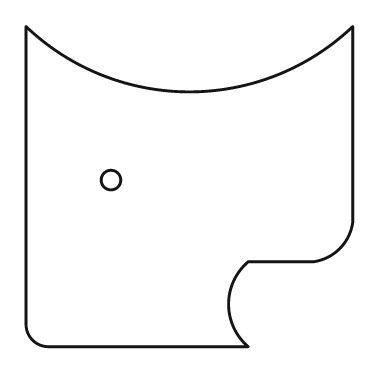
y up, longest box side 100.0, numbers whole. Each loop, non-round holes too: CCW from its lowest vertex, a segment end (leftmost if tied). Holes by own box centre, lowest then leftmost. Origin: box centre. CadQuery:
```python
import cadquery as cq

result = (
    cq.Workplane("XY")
    .moveTo(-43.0, -49.0)
    .lineTo(18.0, -49.0)
    .threePointArc((12.0, -36.0), (18.0, -23.0))
    .lineTo(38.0, -23.0)
    .threePointArc((46.0, -19.0), (50.0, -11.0))
    .lineTo(50.0, 49.0)
    .threePointArc((0.0, 29.0), (-50.0, 49.0))
    .lineTo(-50.0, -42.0)
    .threePointArc((-48.0, -47.0), (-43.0, -49.0))
    .close()
    .moveTo(-24.0, 2.0)
    .circle(3.0)
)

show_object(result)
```